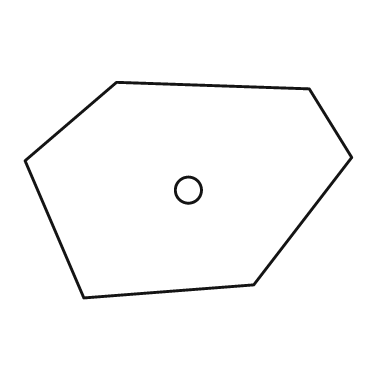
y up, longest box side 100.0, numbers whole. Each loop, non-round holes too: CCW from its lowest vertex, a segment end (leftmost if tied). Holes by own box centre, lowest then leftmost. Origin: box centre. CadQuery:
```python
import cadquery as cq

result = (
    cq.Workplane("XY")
    .moveTo(-32.0, -33.0)
    .lineTo(20.0, -29.0)
    .lineTo(50.0, 10.0)
    .lineTo(37.0, 31.0)
    .lineTo(-22.0, 33.0)
    .lineTo(-50.0, 9.0)
    .close()
    .moveTo(0.0, 0.0)
    .circle(4.0)
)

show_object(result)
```